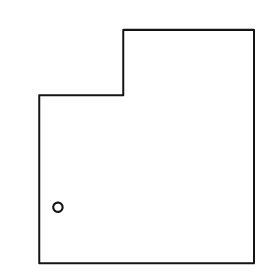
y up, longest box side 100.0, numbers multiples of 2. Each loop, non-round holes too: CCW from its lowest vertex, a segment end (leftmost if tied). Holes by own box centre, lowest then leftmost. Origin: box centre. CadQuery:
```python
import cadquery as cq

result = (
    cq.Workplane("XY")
    .moveTo(-46.0, -50.0)
    .lineTo(46.0, -50.0)
    .lineTo(46.0, 50.0)
    .lineTo(-10.0, 50.0)
    .lineTo(-10.0, 22.0)
    .lineTo(-46.0, 22.0)
    .close()
    .moveTo(-38.0, -26.0)
    .circle(2.0)
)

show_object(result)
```